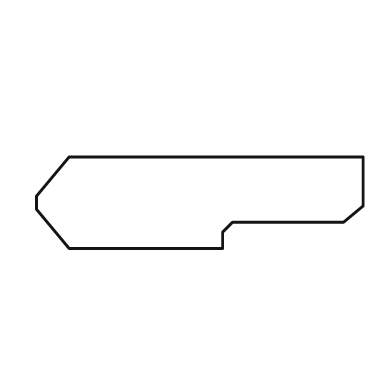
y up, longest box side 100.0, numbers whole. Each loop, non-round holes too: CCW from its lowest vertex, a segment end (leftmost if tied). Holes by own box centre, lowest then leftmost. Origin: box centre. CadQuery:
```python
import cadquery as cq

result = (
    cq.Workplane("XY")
    .moveTo(-40.0, -14.0)
    .lineTo(7.0, -14.0)
    .lineTo(7.0, -9.0)
    .lineTo(10.0, -6.0)
    .lineTo(44.0, -6.0)
    .lineTo(50.0, -1.0)
    .lineTo(50.0, 14.0)
    .lineTo(-40.0, 14.0)
    .lineTo(-50.0, 2.0)
    .lineTo(-50.0, -2.0)
    .close()
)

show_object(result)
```